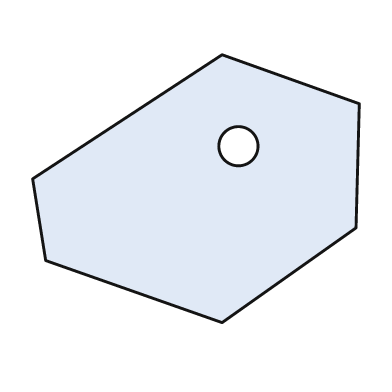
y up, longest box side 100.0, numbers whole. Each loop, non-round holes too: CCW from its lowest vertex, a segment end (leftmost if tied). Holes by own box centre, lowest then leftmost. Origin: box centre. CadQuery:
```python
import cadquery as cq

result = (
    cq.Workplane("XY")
    .moveTo(8.0, -41.0)
    .lineTo(49.0, -12.0)
    .lineTo(50.0, 26.0)
    .lineTo(8.0, 41.0)
    .lineTo(-50.0, 3.0)
    .lineTo(-46.0, -22.0)
    .close()
    .moveTo(13.0, 13.0)
    .circle(6.0)
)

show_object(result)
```